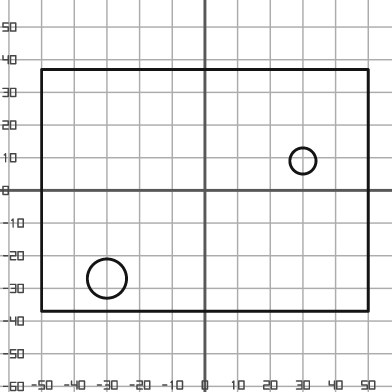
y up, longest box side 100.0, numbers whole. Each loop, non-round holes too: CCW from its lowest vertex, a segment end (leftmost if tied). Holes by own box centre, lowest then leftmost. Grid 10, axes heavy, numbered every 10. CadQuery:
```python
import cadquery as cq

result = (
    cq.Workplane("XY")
    .moveTo(-50.0, -37.0)
    .lineTo(50.0, -37.0)
    .lineTo(50.0, 37.0)
    .lineTo(-50.0, 37.0)
    .close()
    .moveTo(-30.0, -27.0)
    .circle(6.0)
    .moveTo(30.0, 9.0)
    .circle(4.0)
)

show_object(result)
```